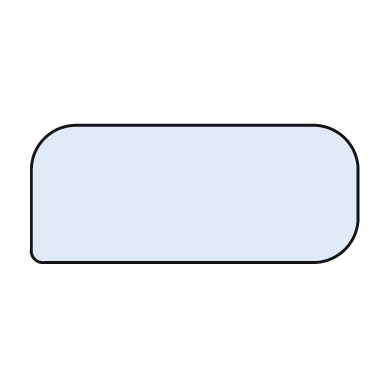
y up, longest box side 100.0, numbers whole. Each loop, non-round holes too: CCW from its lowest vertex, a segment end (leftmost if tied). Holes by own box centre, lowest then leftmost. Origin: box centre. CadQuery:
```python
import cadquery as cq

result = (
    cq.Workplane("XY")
    .moveTo(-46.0, -21.0)
    .lineTo(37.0, -21.0)
    .threePointArc((46.0, -17.0), (50.0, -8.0))
    .lineTo(50.0, 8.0)
    .threePointArc((46.0, 17.0), (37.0, 21.0))
    .lineTo(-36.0, 21.0)
    .threePointArc((-46.0, 17.0), (-50.0, 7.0))
    .lineTo(-50.0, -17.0)
    .threePointArc((-49.0, -20.0), (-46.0, -21.0))
    .close()
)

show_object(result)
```